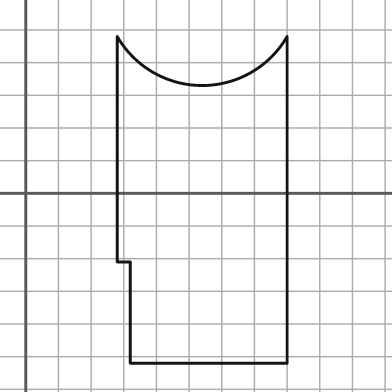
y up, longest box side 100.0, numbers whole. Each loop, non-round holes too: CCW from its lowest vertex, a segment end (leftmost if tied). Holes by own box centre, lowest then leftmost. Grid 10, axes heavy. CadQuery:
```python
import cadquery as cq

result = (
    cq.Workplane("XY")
    .moveTo(32.0, -52.0)
    .lineTo(80.0, -52.0)
    .lineTo(80.0, 48.0)
    .threePointArc((54.0, 33.0), (28.0, 48.0))
    .lineTo(28.0, -21.0)
    .lineTo(32.0, -21.0)
    .close()
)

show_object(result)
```